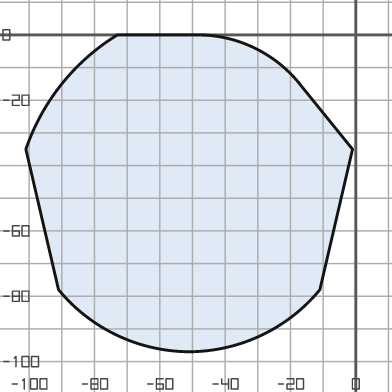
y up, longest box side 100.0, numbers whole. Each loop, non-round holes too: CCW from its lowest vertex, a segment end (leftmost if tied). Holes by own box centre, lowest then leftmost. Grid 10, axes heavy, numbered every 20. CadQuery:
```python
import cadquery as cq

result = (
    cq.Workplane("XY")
    .moveTo(-51.0, -97.0)
    .threePointArc((-29.0, -92.0), (-11.0, -78.0))
    .lineTo(-1.0, -35.0)
    .lineTo(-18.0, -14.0)
    .threePointArc((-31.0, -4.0), (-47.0, 0.0))
    .lineTo(-73.0, 0.0)
    .threePointArc((-90.0, -15.0), (-101.0, -35.0))
    .lineTo(-91.0, -78.0)
    .threePointArc((-73.0, -92.0), (-51.0, -97.0))
    .close()
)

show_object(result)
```